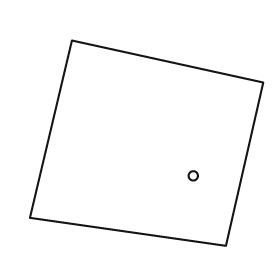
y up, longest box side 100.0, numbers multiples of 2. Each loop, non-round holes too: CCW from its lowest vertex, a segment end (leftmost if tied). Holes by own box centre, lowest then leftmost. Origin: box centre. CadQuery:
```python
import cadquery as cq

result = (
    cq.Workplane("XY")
    .moveTo(34.0, -44.0)
    .lineTo(50.0, 26.0)
    .lineTo(-32.0, 44.0)
    .lineTo(-50.0, -32.0)
    .close()
    .moveTo(20.0, -14.0)
    .circle(2.0)
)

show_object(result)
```